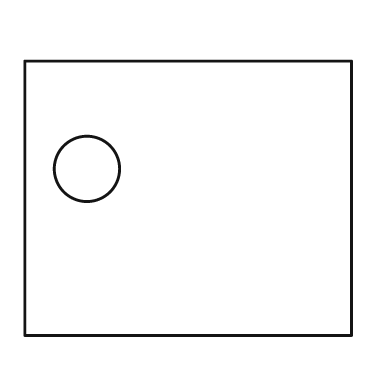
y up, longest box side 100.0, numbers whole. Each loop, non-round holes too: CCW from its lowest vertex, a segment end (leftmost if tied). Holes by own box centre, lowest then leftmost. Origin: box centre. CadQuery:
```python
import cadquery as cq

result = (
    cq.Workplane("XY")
    .moveTo(-50.0, -42.0)
    .lineTo(50.0, -42.0)
    .lineTo(50.0, 42.0)
    .lineTo(-50.0, 42.0)
    .close()
    .moveTo(-31.0, 9.0)
    .circle(10.0)
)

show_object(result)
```